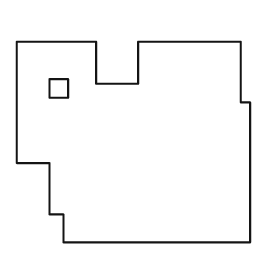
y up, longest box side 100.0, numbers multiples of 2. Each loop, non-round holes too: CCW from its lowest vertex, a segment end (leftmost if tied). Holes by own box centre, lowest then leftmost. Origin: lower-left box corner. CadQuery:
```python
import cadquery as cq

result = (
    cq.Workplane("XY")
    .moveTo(20.0, 0.0)
    .lineTo(100.0, 0.0)
    .lineTo(100.0, 60.0)
    .lineTo(96.0, 60.0)
    .lineTo(96.0, 86.0)
    .lineTo(52.0, 86.0)
    .lineTo(52.0, 68.0)
    .lineTo(34.0, 68.0)
    .lineTo(34.0, 86.0)
    .lineTo(0.0, 86.0)
    .lineTo(0.0, 34.0)
    .lineTo(14.0, 34.0)
    .lineTo(14.0, 12.0)
    .lineTo(20.0, 12.0)
    .close()
    .moveTo(14.0, 62.0)
    .lineTo(22.0, 62.0)
    .lineTo(22.0, 70.0)
    .lineTo(14.0, 70.0)
    .close()
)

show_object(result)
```